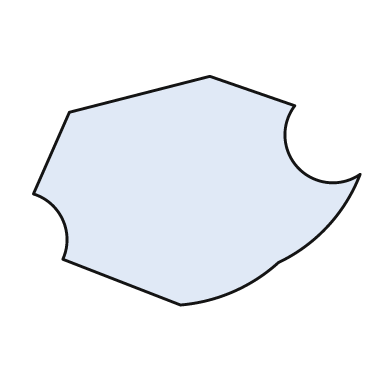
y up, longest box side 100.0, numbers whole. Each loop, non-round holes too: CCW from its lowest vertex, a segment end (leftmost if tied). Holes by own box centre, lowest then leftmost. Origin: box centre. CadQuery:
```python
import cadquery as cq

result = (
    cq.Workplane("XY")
    .moveTo(-5.0, -35.0)
    .threePointArc((11.0, -31.0), (25.0, -22.0))
    .threePointArc((40.0, -11.0), (50.0, 5.0))
    .threePointArc((31.0, 7.0), (30.0, 26.0))
    .lineTo(4.0, 35.0)
    .lineTo(-39.0, 24.0)
    .lineTo(-50.0, -1.0)
    .threePointArc((-41.0, -9.0), (-41.0, -21.0))
    .close()
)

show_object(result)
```